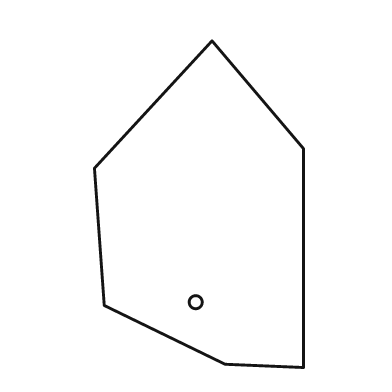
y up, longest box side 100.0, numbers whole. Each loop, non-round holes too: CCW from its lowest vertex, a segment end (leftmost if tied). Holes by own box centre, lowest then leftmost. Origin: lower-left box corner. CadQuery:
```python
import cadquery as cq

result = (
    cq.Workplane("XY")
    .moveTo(64.0, 0.0)
    .lineTo(64.0, 67.0)
    .lineTo(36.0, 100.0)
    .lineTo(0.0, 61.0)
    .lineTo(3.0, 19.0)
    .lineTo(40.0, 1.0)
    .close()
    .moveTo(31.0, 20.0)
    .circle(2.0)
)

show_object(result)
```